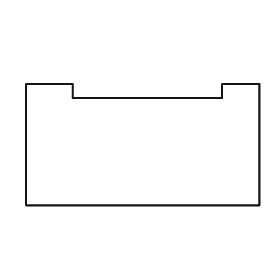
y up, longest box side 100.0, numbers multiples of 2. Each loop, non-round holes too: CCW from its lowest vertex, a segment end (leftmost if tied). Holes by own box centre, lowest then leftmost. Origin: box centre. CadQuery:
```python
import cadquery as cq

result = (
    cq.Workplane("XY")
    .moveTo(-50.0, -26.0)
    .lineTo(50.0, -26.0)
    .lineTo(50.0, 26.0)
    .lineTo(34.0, 26.0)
    .lineTo(34.0, 20.0)
    .lineTo(-30.0, 20.0)
    .lineTo(-30.0, 26.0)
    .lineTo(-50.0, 26.0)
    .close()
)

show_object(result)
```